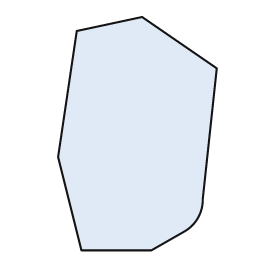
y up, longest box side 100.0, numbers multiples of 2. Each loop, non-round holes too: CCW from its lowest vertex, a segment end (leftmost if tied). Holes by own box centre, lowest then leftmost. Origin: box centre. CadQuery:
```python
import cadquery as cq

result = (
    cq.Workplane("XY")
    .moveTo(-24.0, -50.0)
    .lineTo(6.0, -50.0)
    .lineTo(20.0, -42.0)
    .threePointArc((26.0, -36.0), (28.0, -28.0))
    .lineTo(34.0, 28.0)
    .lineTo(2.0, 50.0)
    .lineTo(-26.0, 44.0)
    .lineTo(-34.0, -10.0)
    .close()
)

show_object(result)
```